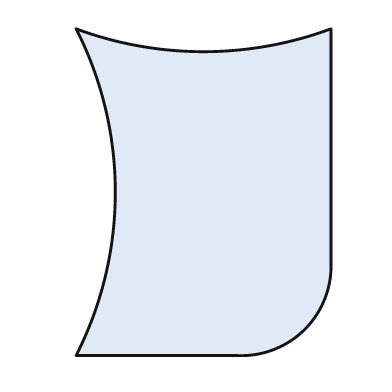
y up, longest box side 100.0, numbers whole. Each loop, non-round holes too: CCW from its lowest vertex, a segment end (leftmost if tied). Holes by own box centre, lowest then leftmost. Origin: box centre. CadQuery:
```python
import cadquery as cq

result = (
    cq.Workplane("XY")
    .moveTo(-39.0, -50.0)
    .lineTo(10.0, -50.0)
    .threePointArc((31.0, -42.0), (39.0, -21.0))
    .lineTo(39.0, 50.0)
    .threePointArc((0.0, 43.0), (-39.0, 50.0))
    .threePointArc((-27.0, 0.0), (-39.0, -50.0))
    .close()
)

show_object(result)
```